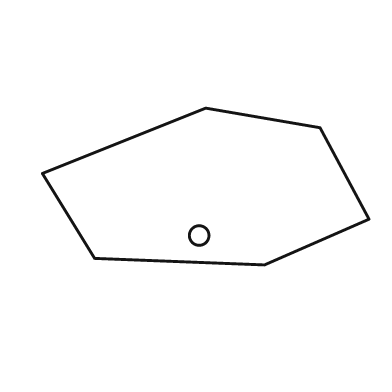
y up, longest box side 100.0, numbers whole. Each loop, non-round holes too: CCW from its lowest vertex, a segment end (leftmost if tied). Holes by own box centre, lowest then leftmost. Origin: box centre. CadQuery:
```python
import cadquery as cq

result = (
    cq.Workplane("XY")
    .moveTo(18.0, -24.0)
    .lineTo(50.0, -10.0)
    .lineTo(35.0, 18.0)
    .lineTo(0.0, 24.0)
    .lineTo(-50.0, 4.0)
    .lineTo(-34.0, -22.0)
    .close()
    .moveTo(-2.0, -15.0)
    .circle(3.0)
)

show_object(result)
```